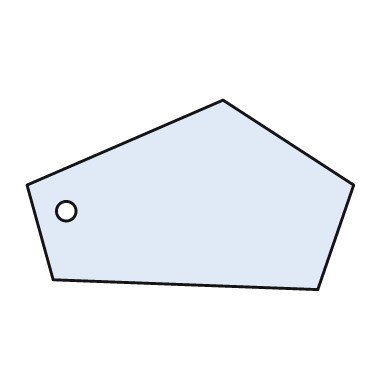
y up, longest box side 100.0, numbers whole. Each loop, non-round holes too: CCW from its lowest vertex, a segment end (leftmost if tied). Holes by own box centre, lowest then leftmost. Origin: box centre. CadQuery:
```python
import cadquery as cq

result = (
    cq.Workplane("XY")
    .moveTo(39.0, -29.0)
    .lineTo(50.0, 3.0)
    .lineTo(10.0, 29.0)
    .lineTo(-50.0, 3.0)
    .lineTo(-42.0, -26.0)
    .close()
    .moveTo(-38.0, -5.0)
    .circle(3.0)
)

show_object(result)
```